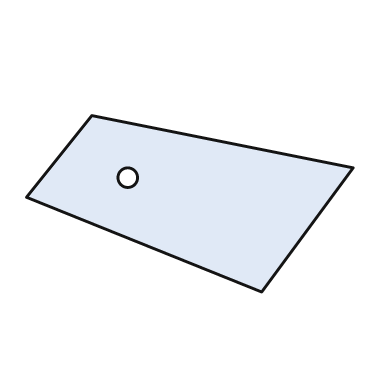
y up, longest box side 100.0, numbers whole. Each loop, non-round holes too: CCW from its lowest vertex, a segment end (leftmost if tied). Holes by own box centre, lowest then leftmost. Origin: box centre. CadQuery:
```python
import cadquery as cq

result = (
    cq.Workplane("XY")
    .moveTo(22.0, -27.0)
    .lineTo(50.0, 11.0)
    .lineTo(-30.0, 27.0)
    .lineTo(-50.0, 2.0)
    .close()
    .moveTo(-19.0, 8.0)
    .circle(3.0)
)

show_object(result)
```